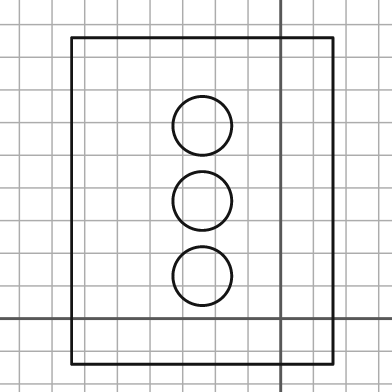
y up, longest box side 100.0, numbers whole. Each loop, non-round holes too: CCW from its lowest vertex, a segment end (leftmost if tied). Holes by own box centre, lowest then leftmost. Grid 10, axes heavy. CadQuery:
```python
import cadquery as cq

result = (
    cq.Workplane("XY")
    .moveTo(-64.0, -14.0)
    .lineTo(16.0, -14.0)
    .lineTo(16.0, 86.0)
    .lineTo(-64.0, 86.0)
    .close()
    .moveTo(-24.0, 13.0)
    .circle(9.0)
    .moveTo(-24.0, 36.0)
    .circle(9.0)
    .moveTo(-24.0, 59.0)
    .circle(9.0)
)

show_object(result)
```